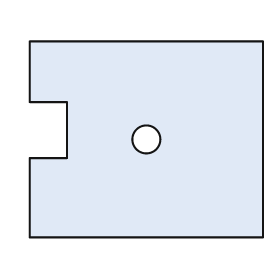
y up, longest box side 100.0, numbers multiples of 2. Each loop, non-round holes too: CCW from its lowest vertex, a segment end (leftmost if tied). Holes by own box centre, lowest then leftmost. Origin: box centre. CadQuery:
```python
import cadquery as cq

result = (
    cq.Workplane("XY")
    .moveTo(-50.0, -42.0)
    .lineTo(50.0, -42.0)
    .lineTo(50.0, 42.0)
    .lineTo(-50.0, 42.0)
    .lineTo(-50.0, 16.0)
    .lineTo(-34.0, 16.0)
    .lineTo(-34.0, -8.0)
    .lineTo(-50.0, -8.0)
    .close()
    .moveTo(0.0, 0.0)
    .circle(6.0)
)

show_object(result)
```